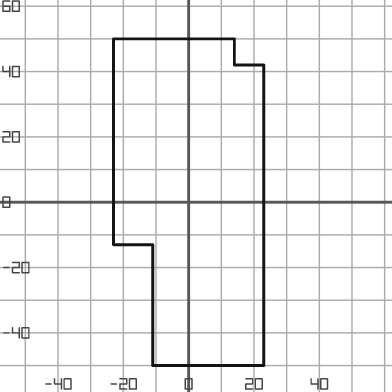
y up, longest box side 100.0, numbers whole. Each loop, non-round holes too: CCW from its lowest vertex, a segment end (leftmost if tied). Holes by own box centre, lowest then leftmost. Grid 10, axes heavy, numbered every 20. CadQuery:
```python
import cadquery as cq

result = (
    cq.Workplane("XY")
    .moveTo(-11.0, -50.0)
    .lineTo(23.0, -50.0)
    .lineTo(23.0, 42.0)
    .lineTo(14.0, 42.0)
    .lineTo(14.0, 50.0)
    .lineTo(-23.0, 50.0)
    .lineTo(-23.0, -13.0)
    .lineTo(-11.0, -13.0)
    .close()
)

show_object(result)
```